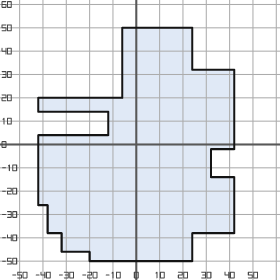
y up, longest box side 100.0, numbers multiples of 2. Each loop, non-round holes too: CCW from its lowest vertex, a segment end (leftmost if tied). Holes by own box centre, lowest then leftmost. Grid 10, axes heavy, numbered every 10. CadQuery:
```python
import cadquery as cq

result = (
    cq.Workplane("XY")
    .moveTo(-20.0, -50.0)
    .lineTo(24.0, -50.0)
    .lineTo(24.0, -38.0)
    .lineTo(42.0, -38.0)
    .lineTo(42.0, -14.0)
    .lineTo(32.0, -14.0)
    .lineTo(32.0, -2.0)
    .lineTo(42.0, -2.0)
    .lineTo(42.0, 32.0)
    .lineTo(24.0, 32.0)
    .lineTo(24.0, 50.0)
    .lineTo(-6.0, 50.0)
    .lineTo(-6.0, 20.0)
    .lineTo(-42.0, 20.0)
    .lineTo(-42.0, 14.0)
    .lineTo(-12.0, 14.0)
    .lineTo(-12.0, 4.0)
    .lineTo(-42.0, 4.0)
    .lineTo(-42.0, -26.0)
    .lineTo(-38.0, -26.0)
    .lineTo(-38.0, -38.0)
    .lineTo(-32.0, -38.0)
    .lineTo(-32.0, -46.0)
    .lineTo(-20.0, -46.0)
    .close()
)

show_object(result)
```